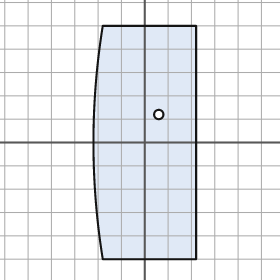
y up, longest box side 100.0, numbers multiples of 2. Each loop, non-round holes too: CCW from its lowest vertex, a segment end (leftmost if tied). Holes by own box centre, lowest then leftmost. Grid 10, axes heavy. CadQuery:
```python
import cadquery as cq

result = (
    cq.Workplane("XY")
    .moveTo(-18.0, -50.0)
    .lineTo(22.0, -50.0)
    .lineTo(22.0, 50.0)
    .lineTo(-18.0, 50.0)
    .threePointArc((-22.0, 0.0), (-18.0, -50.0))
    .close()
    .moveTo(6.0, 12.0)
    .circle(2.0)
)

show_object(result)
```